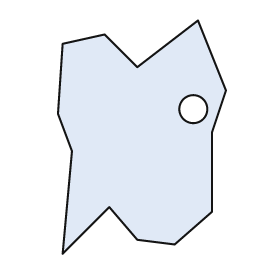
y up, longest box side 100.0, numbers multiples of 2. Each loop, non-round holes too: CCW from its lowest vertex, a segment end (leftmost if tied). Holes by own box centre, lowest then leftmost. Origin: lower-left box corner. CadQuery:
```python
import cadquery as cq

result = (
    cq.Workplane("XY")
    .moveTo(2.0, 0.0)
    .lineTo(22.0, 20.0)
    .lineTo(34.0, 6.0)
    .lineTo(50.0, 4.0)
    .lineTo(66.0, 18.0)
    .lineTo(66.0, 52.0)
    .lineTo(72.0, 70.0)
    .lineTo(60.0, 100.0)
    .lineTo(34.0, 80.0)
    .lineTo(20.0, 94.0)
    .lineTo(2.0, 90.0)
    .lineTo(0.0, 60.0)
    .lineTo(6.0, 44.0)
    .close()
    .moveTo(58.0, 62.0)
    .circle(6.0)
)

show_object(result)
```